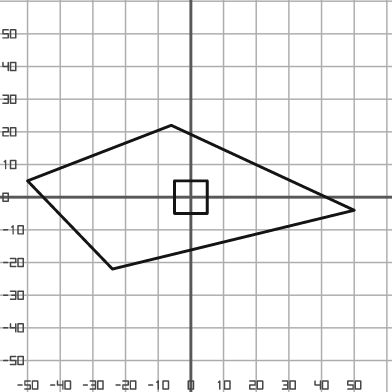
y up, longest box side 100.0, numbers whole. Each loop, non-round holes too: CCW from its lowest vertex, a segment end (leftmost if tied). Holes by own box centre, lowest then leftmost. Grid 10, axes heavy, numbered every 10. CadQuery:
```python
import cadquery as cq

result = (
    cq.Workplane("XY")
    .moveTo(-24.0, -22.0)
    .lineTo(50.0, -4.0)
    .lineTo(-6.0, 22.0)
    .lineTo(-50.0, 5.0)
    .close()
    .moveTo(-5.0, -5.0)
    .lineTo(5.0, -5.0)
    .lineTo(5.0, 5.0)
    .lineTo(-5.0, 5.0)
    .close()
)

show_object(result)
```